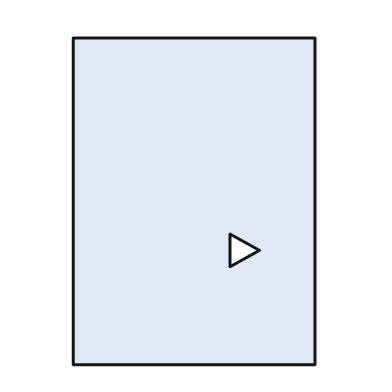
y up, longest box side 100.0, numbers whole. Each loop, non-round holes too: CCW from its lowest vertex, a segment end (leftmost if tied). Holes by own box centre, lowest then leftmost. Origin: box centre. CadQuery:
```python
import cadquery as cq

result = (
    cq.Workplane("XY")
    .moveTo(-37.0, -50.0)
    .lineTo(37.0, -50.0)
    .lineTo(37.0, 50.0)
    .lineTo(-37.0, 50.0)
    .close()
    .moveTo(11.0, -20.0)
    .lineTo(20.0, -15.0)
    .lineTo(11.0, -10.0)
    .close()
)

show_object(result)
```